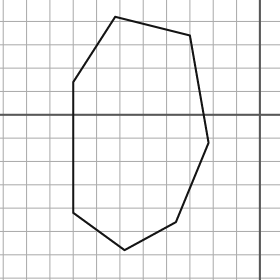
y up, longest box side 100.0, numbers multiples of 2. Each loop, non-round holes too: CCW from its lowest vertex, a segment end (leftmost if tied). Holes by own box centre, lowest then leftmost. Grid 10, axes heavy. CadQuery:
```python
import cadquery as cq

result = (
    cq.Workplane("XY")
    .moveTo(-58.0, -58.0)
    .lineTo(-36.0, -46.0)
    .lineTo(-22.0, -12.0)
    .lineTo(-30.0, 34.0)
    .lineTo(-62.0, 42.0)
    .lineTo(-80.0, 14.0)
    .lineTo(-80.0, -42.0)
    .close()
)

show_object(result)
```